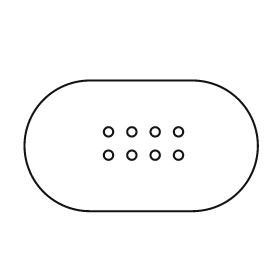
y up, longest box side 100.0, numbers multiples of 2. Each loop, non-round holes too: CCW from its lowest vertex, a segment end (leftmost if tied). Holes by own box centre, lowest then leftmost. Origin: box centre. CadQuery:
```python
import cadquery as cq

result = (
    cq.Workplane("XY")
    .moveTo(-22.0, -28.0)
    .lineTo(22.0, -28.0)
    .threePointArc((50.0, 0.0), (22.0, 28.0))
    .lineTo(-22.0, 28.0)
    .threePointArc((-50.0, 0.0), (-22.0, -28.0))
    .close()
    .moveTo(-14.0, -4.0)
    .circle(2.0)
    .moveTo(-4.0, -4.0)
    .circle(2.0)
    .moveTo(6.0, -4.0)
    .circle(2.0)
    .moveTo(16.0, -4.0)
    .circle(2.0)
    .moveTo(-14.0, 6.0)
    .circle(2.0)
    .moveTo(-4.0, 6.0)
    .circle(2.0)
    .moveTo(6.0, 6.0)
    .circle(2.0)
    .moveTo(16.0, 6.0)
    .circle(2.0)
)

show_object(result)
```